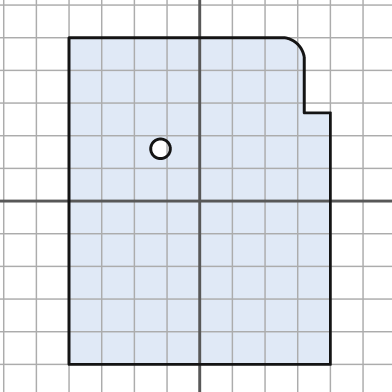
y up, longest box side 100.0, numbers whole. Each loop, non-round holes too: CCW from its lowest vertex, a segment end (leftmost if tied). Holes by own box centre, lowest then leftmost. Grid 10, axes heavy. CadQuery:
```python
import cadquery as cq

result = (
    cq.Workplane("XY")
    .moveTo(-40.0, -50.0)
    .lineTo(40.0, -50.0)
    .lineTo(40.0, 27.0)
    .lineTo(32.0, 27.0)
    .lineTo(32.0, 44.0)
    .threePointArc((30.0, 48.0), (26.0, 50.0))
    .lineTo(-40.0, 50.0)
    .close()
    .moveTo(-12.0, 16.0)
    .circle(3.0)
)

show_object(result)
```